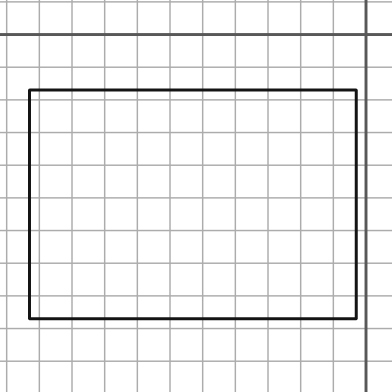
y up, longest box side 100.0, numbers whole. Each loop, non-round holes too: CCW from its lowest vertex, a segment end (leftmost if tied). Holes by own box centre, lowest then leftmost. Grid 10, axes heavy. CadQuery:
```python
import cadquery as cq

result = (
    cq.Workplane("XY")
    .moveTo(-103.0, -87.0)
    .lineTo(-3.0, -87.0)
    .lineTo(-3.0, -17.0)
    .lineTo(-103.0, -17.0)
    .close()
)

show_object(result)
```